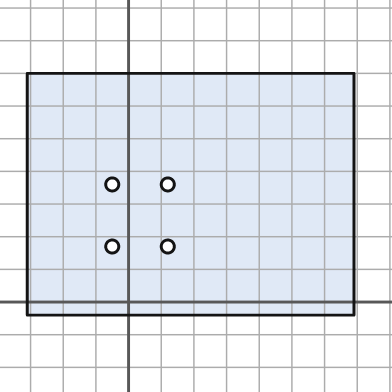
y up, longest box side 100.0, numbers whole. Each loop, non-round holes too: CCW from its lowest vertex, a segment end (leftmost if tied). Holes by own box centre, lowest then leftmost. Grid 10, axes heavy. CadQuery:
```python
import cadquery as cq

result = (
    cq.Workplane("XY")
    .moveTo(-31.0, -4.0)
    .lineTo(69.0, -4.0)
    .lineTo(69.0, 70.0)
    .lineTo(-31.0, 70.0)
    .close()
    .moveTo(-5.0, 17.0)
    .circle(2.0)
    .moveTo(12.0, 17.0)
    .circle(2.0)
    .moveTo(-5.0, 36.0)
    .circle(2.0)
    .moveTo(12.0, 36.0)
    .circle(2.0)
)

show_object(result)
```